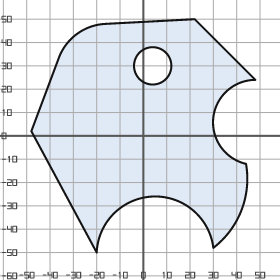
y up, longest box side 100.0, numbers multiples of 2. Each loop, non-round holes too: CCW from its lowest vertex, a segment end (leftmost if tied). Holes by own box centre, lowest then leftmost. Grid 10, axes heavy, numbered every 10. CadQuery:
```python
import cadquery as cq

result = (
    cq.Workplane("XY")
    .moveTo(-20.0, -50.0)
    .threePointArc((4.0, -26.0), (30.0, -48.0))
    .threePointArc((42.0, -32.0), (44.0, -12.0))
    .threePointArc((30.0, 8.0), (48.0, 24.0))
    .lineTo(22.0, 50.0)
    .lineTo(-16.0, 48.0)
    .threePointArc((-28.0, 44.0), (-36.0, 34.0))
    .lineTo(-48.0, 2.0)
    .close()
    .moveTo(4.0, 30.0)
    .circle(8.0)
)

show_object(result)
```